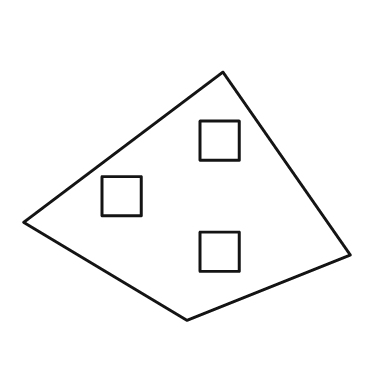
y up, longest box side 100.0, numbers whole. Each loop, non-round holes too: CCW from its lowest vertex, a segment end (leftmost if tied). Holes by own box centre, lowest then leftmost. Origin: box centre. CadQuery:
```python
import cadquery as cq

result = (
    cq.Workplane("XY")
    .moveTo(0.0, -38.0)
    .lineTo(50.0, -18.0)
    .lineTo(11.0, 38.0)
    .lineTo(-50.0, -8.0)
    .close()
    .moveTo(4.0, -23.0)
    .lineTo(16.0, -23.0)
    .lineTo(16.0, -11.0)
    .lineTo(4.0, -11.0)
    .close()
    .moveTo(-26.0, -6.0)
    .lineTo(-14.0, -6.0)
    .lineTo(-14.0, 6.0)
    .lineTo(-26.0, 6.0)
    .close()
    .moveTo(4.0, 11.0)
    .lineTo(16.0, 11.0)
    .lineTo(16.0, 23.0)
    .lineTo(4.0, 23.0)
    .close()
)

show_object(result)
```